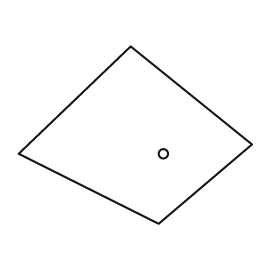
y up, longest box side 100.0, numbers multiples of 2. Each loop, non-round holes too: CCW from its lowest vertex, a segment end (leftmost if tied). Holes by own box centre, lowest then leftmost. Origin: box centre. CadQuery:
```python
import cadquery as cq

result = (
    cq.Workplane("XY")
    .moveTo(10.0, -38.0)
    .lineTo(50.0, -4.0)
    .lineTo(-2.0, 38.0)
    .lineTo(-50.0, -8.0)
    .close()
    .moveTo(12.0, -8.0)
    .circle(2.0)
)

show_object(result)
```